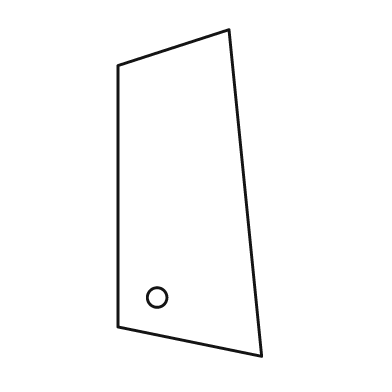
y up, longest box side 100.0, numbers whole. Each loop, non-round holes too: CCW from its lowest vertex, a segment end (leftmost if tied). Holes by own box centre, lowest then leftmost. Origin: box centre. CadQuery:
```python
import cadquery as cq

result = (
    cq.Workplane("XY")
    .moveTo(22.0, -50.0)
    .lineTo(12.0, 50.0)
    .lineTo(-22.0, 39.0)
    .lineTo(-22.0, -41.0)
    .close()
    .moveTo(-10.0, -32.0)
    .circle(3.0)
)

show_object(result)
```